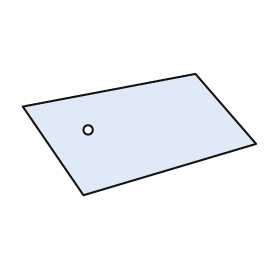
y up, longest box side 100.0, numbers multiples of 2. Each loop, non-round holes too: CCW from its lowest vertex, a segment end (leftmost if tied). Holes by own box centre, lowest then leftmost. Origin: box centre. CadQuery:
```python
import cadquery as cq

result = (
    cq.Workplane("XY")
    .moveTo(-24.0, -26.0)
    .lineTo(50.0, -4.0)
    .lineTo(24.0, 26.0)
    .lineTo(-50.0, 12.0)
    .close()
    .moveTo(-22.0, 2.0)
    .circle(2.0)
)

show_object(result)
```